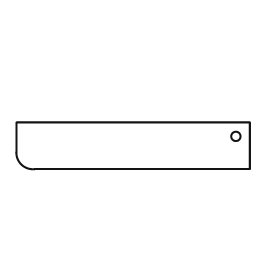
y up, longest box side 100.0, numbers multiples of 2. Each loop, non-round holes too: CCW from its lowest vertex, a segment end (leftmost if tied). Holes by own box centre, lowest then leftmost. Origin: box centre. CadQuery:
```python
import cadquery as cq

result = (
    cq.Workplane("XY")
    .moveTo(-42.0, -10.0)
    .lineTo(50.0, -10.0)
    .lineTo(50.0, 10.0)
    .lineTo(-50.0, 10.0)
    .lineTo(-50.0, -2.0)
    .threePointArc((-48.0, -8.0), (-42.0, -10.0))
    .close()
    .moveTo(44.0, 4.0)
    .circle(2.0)
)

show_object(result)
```